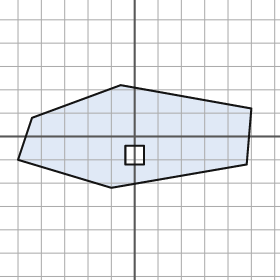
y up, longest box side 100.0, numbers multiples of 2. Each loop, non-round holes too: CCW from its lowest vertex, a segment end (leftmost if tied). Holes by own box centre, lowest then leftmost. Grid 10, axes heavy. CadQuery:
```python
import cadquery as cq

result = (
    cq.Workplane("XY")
    .moveTo(-10.0, -22.0)
    .lineTo(48.0, -12.0)
    .lineTo(50.0, 12.0)
    .lineTo(-6.0, 22.0)
    .lineTo(-44.0, 8.0)
    .lineTo(-50.0, -10.0)
    .close()
    .moveTo(-4.0, -12.0)
    .lineTo(4.0, -12.0)
    .lineTo(4.0, -4.0)
    .lineTo(-4.0, -4.0)
    .close()
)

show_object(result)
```